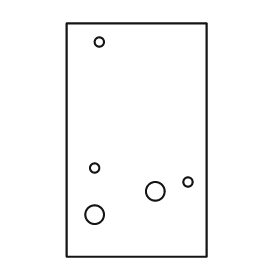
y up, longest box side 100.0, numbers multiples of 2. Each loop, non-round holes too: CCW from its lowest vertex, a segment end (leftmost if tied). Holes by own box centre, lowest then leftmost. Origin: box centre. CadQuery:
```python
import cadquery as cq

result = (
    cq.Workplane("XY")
    .moveTo(-30.0, -50.0)
    .lineTo(30.0, -50.0)
    .lineTo(30.0, 50.0)
    .lineTo(-30.0, 50.0)
    .close()
    .moveTo(-18.0, -32.0)
    .circle(4.0)
    .moveTo(8.0, -22.0)
    .circle(4.0)
    .moveTo(22.0, -18.0)
    .circle(2.0)
    .moveTo(-18.0, -12.0)
    .circle(2.0)
    .moveTo(-16.0, 42.0)
    .circle(2.0)
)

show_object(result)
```